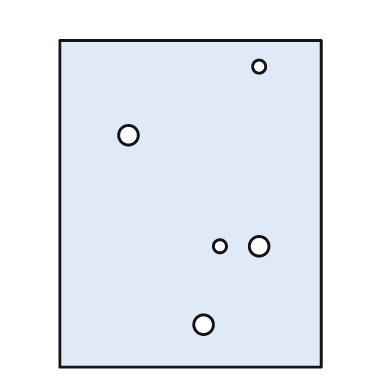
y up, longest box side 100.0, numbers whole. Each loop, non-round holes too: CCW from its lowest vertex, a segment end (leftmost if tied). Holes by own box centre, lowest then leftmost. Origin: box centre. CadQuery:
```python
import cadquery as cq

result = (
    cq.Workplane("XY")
    .moveTo(-40.0, -50.0)
    .lineTo(40.0, -50.0)
    .lineTo(40.0, 50.0)
    .lineTo(-40.0, 50.0)
    .close()
    .moveTo(4.0, -37.0)
    .circle(3.0)
    .moveTo(9.0, -13.0)
    .circle(2.0)
    .moveTo(21.0, -13.0)
    .circle(3.0)
    .moveTo(-19.0, 21.0)
    .circle(3.0)
    .moveTo(21.0, 42.0)
    .circle(2.0)
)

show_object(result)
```